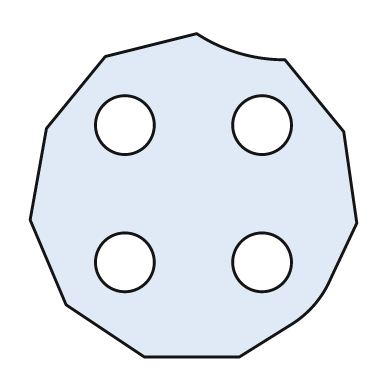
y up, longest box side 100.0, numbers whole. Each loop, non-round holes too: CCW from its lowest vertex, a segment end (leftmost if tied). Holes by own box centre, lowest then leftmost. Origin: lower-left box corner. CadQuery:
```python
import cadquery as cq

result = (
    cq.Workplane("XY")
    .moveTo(35.0, 0.0)
    .lineTo(64.0, 0.0)
    .lineTo(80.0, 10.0)
    .threePointArc((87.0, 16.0), (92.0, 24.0))
    .lineTo(100.0, 41.0)
    .lineTo(96.0, 69.0)
    .lineTo(78.0, 91.0)
    .threePointArc((64.0, 93.0), (51.0, 99.0))
    .lineTo(23.0, 92.0)
    .lineTo(5.0, 70.0)
    .lineTo(0.0, 42.0)
    .lineTo(11.0, 16.0)
    .close()
    .moveTo(29.0, 29.0)
    .circle(9.0)
    .moveTo(71.0, 29.0)
    .circle(9.0)
    .moveTo(29.0, 71.0)
    .circle(9.0)
    .moveTo(71.0, 71.0)
    .circle(9.0)
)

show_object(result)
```